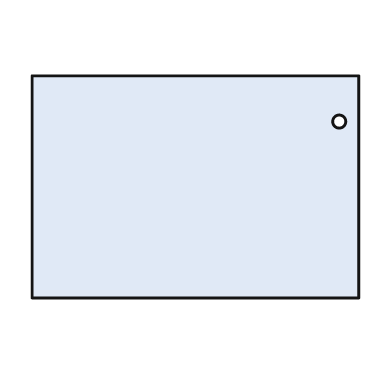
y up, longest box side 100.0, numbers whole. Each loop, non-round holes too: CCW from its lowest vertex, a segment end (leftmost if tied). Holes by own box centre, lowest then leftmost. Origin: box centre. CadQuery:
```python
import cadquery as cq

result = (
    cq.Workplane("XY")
    .moveTo(-50.0, -34.0)
    .lineTo(50.0, -34.0)
    .lineTo(50.0, 34.0)
    .lineTo(-50.0, 34.0)
    .close()
    .moveTo(44.0, 20.0)
    .circle(2.0)
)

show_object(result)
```